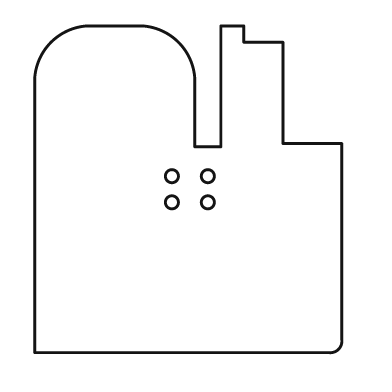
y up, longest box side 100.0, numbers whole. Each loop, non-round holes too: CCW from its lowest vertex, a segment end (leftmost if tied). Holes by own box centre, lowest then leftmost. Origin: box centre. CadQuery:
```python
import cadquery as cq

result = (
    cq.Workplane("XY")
    .moveTo(-47.0, -50.0)
    .lineTo(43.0, -50.0)
    .threePointArc((46.0, -49.0), (47.0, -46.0))
    .lineTo(47.0, 14.0)
    .lineTo(29.0, 14.0)
    .lineTo(29.0, 45.0)
    .lineTo(17.0, 45.0)
    .lineTo(17.0, 50.0)
    .lineTo(10.0, 50.0)
    .lineTo(10.0, 13.0)
    .lineTo(2.0, 13.0)
    .lineTo(2.0, 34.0)
    .threePointArc((-3.0, 45.0), (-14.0, 50.0))
    .lineTo(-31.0, 50.0)
    .threePointArc((-42.0, 45.0), (-47.0, 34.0))
    .close()
    .moveTo(-5.0, -4.0)
    .circle(2.0)
    .moveTo(6.0, -4.0)
    .circle(2.0)
    .moveTo(-5.0, 4.0)
    .circle(2.0)
    .moveTo(6.0, 4.0)
    .circle(2.0)
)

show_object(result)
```